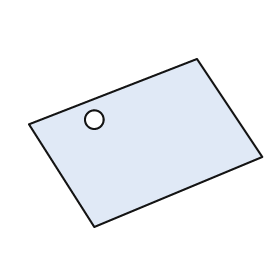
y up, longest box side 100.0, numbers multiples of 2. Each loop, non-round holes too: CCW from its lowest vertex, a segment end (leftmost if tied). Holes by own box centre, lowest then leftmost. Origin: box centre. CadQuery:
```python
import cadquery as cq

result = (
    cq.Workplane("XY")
    .moveTo(-22.0, -36.0)
    .lineTo(50.0, -6.0)
    .lineTo(22.0, 36.0)
    .lineTo(-50.0, 8.0)
    .close()
    .moveTo(-22.0, 10.0)
    .circle(4.0)
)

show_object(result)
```